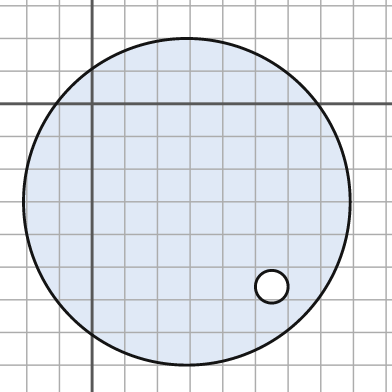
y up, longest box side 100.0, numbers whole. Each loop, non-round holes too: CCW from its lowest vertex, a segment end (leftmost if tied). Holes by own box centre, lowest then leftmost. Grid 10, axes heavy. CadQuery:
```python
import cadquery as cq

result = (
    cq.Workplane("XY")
    .moveTo(29.0, -30.0)
    .circle(50.0)
    .moveTo(55.0, -56.0)
    .circle(5.0)
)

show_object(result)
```